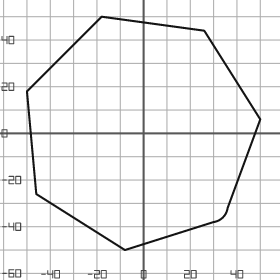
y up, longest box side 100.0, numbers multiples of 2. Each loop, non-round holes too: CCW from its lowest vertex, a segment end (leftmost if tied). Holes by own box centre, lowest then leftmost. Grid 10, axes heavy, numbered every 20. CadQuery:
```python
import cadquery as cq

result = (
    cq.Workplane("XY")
    .moveTo(-8.0, -50.0)
    .lineTo(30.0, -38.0)
    .threePointArc((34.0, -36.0), (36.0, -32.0))
    .lineTo(50.0, 6.0)
    .lineTo(26.0, 44.0)
    .lineTo(-18.0, 50.0)
    .lineTo(-50.0, 18.0)
    .lineTo(-46.0, -26.0)
    .close()
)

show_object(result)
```